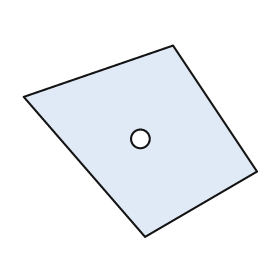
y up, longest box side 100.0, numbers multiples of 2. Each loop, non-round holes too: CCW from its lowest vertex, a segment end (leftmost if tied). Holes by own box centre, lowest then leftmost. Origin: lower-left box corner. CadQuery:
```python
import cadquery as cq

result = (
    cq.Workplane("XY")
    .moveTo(52.0, 0.0)
    .lineTo(100.0, 28.0)
    .lineTo(64.0, 82.0)
    .lineTo(0.0, 60.0)
    .close()
    .moveTo(50.0, 42.0)
    .circle(4.0)
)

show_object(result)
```